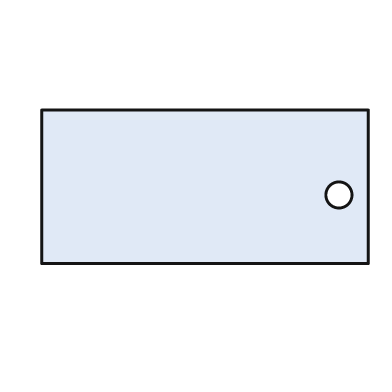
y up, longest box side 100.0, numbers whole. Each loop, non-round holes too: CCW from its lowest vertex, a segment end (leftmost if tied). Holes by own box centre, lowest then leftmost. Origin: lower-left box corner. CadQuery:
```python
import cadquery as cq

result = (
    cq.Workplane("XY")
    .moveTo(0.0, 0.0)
    .lineTo(100.0, 0.0)
    .lineTo(100.0, 47.0)
    .lineTo(0.0, 47.0)
    .close()
    .moveTo(91.0, 21.0)
    .circle(4.0)
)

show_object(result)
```